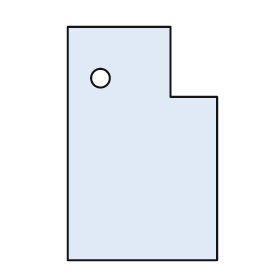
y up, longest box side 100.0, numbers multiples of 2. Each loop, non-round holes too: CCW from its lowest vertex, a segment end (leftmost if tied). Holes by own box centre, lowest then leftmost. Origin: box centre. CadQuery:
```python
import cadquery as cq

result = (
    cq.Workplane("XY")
    .moveTo(-32.0, -50.0)
    .lineTo(32.0, -50.0)
    .lineTo(32.0, 20.0)
    .lineTo(12.0, 20.0)
    .lineTo(12.0, 50.0)
    .lineTo(-32.0, 50.0)
    .close()
    .moveTo(-18.0, 28.0)
    .circle(4.0)
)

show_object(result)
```